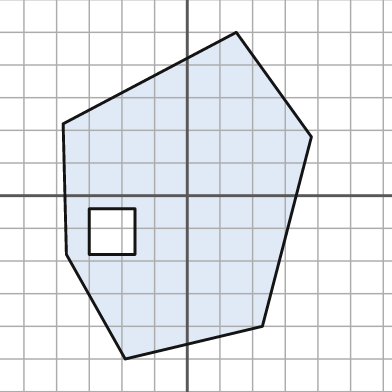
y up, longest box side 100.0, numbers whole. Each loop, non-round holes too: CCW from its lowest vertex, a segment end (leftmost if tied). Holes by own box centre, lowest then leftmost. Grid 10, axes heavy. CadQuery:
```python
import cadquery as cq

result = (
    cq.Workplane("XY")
    .moveTo(-19.0, -50.0)
    .lineTo(23.0, -40.0)
    .lineTo(38.0, 18.0)
    .lineTo(15.0, 50.0)
    .lineTo(-38.0, 22.0)
    .lineTo(-37.0, -18.0)
    .close()
    .moveTo(-30.0, -18.0)
    .lineTo(-16.0, -18.0)
    .lineTo(-16.0, -4.0)
    .lineTo(-30.0, -4.0)
    .close()
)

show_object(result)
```